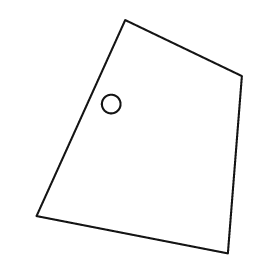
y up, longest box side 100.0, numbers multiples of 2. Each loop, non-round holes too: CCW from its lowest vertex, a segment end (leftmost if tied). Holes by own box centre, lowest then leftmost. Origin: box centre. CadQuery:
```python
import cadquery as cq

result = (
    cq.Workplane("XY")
    .moveTo(38.0, -50.0)
    .lineTo(44.0, 26.0)
    .lineTo(-6.0, 50.0)
    .lineTo(-44.0, -34.0)
    .close()
    .moveTo(-12.0, 14.0)
    .circle(4.0)
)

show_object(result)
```